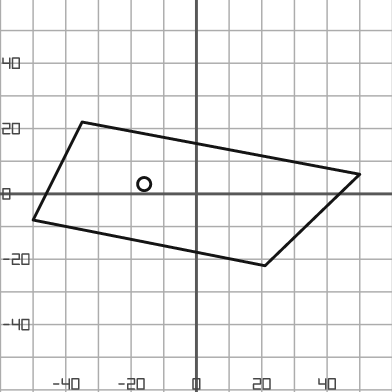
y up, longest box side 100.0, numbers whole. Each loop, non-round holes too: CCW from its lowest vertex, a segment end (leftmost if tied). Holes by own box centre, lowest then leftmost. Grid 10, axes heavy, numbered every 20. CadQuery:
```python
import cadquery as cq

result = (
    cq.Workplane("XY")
    .moveTo(21.0, -22.0)
    .lineTo(50.0, 6.0)
    .lineTo(-35.0, 22.0)
    .lineTo(-50.0, -8.0)
    .close()
    .moveTo(-16.0, 3.0)
    .circle(2.0)
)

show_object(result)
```